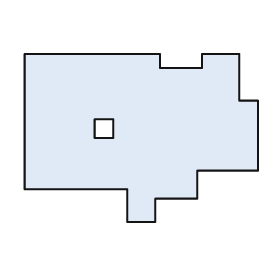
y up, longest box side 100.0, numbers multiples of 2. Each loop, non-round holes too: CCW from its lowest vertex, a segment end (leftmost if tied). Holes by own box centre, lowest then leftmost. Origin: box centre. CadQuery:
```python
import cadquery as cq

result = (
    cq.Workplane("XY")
    .moveTo(-6.0, -36.0)
    .lineTo(6.0, -36.0)
    .lineTo(6.0, -26.0)
    .lineTo(24.0, -26.0)
    .lineTo(24.0, -14.0)
    .lineTo(50.0, -14.0)
    .lineTo(50.0, 16.0)
    .lineTo(42.0, 16.0)
    .lineTo(42.0, 36.0)
    .lineTo(26.0, 36.0)
    .lineTo(26.0, 30.0)
    .lineTo(8.0, 30.0)
    .lineTo(8.0, 36.0)
    .lineTo(-50.0, 36.0)
    .lineTo(-50.0, -22.0)
    .lineTo(-6.0, -22.0)
    .close()
    .moveTo(-20.0, 0.0)
    .lineTo(-12.0, 0.0)
    .lineTo(-12.0, 8.0)
    .lineTo(-20.0, 8.0)
    .close()
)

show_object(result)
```